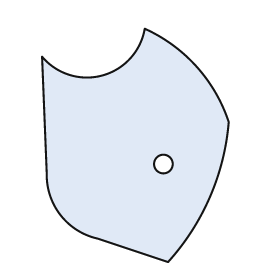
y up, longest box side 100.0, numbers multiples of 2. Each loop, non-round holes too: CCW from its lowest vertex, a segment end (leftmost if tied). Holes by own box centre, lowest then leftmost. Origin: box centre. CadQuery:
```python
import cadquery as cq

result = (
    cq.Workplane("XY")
    .moveTo(14.0, -50.0)
    .threePointArc((32.0, -22.0), (40.0, 10.0))
    .threePointArc((26.0, 34.0), (4.0, 50.0))
    .threePointArc((-14.0, 30.0), (-40.0, 38.0))
    .lineTo(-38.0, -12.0)
    .threePointArc((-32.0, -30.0), (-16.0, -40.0))
    .close()
    .moveTo(12.0, -8.0)
    .circle(4.0)
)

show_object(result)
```